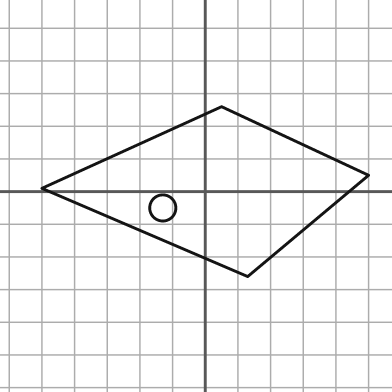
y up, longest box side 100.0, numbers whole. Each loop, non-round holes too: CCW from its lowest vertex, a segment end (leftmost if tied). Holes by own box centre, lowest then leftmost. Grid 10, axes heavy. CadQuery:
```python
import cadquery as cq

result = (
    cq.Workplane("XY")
    .moveTo(13.0, -26.0)
    .lineTo(50.0, 5.0)
    .lineTo(5.0, 26.0)
    .lineTo(-50.0, 1.0)
    .close()
    .moveTo(-13.0, -5.0)
    .circle(4.0)
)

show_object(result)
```